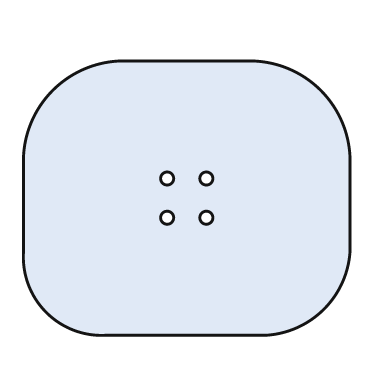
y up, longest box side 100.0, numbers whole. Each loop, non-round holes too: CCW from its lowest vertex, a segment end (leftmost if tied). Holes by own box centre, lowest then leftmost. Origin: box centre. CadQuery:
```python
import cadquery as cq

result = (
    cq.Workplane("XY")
    .moveTo(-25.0, -42.0)
    .lineTo(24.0, -42.0)
    .threePointArc((42.0, -34.0), (50.0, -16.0))
    .lineTo(50.0, 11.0)
    .threePointArc((41.0, 33.0), (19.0, 42.0))
    .lineTo(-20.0, 42.0)
    .threePointArc((-41.0, 33.0), (-50.0, 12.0))
    .lineTo(-50.0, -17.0)
    .threePointArc((-43.0, -35.0), (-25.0, -42.0))
    .close()
    .moveTo(-6.0, -6.0)
    .circle(2.0)
    .moveTo(6.0, -6.0)
    .circle(2.0)
    .moveTo(-6.0, 6.0)
    .circle(2.0)
    .moveTo(6.0, 6.0)
    .circle(2.0)
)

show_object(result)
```